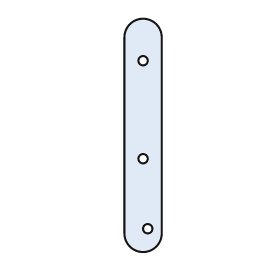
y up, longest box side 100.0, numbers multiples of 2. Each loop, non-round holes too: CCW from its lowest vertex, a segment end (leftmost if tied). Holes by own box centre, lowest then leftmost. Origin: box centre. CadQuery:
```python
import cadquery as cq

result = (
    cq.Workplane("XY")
    .moveTo(-8.0, -42.0)
    .threePointArc((0.0, -50.0), (8.0, -42.0))
    .lineTo(8.0, 42.0)
    .threePointArc((0.0, 50.0), (-8.0, 42.0))
    .close()
    .moveTo(2.0, -40.0)
    .circle(2.0)
    .moveTo(0.0, -10.0)
    .circle(2.0)
    .moveTo(0.0, 32.0)
    .circle(2.0)
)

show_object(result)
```